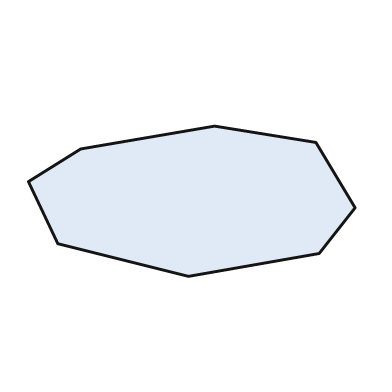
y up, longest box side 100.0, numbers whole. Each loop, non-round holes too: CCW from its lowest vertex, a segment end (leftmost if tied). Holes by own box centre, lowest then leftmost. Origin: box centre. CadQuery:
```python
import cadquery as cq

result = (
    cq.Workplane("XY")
    .moveTo(-1.0, -23.0)
    .lineTo(39.0, -16.0)
    .lineTo(50.0, -2.0)
    .lineTo(38.0, 18.0)
    .lineTo(7.0, 23.0)
    .lineTo(-34.0, 16.0)
    .lineTo(-50.0, 6.0)
    .lineTo(-41.0, -13.0)
    .close()
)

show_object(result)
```